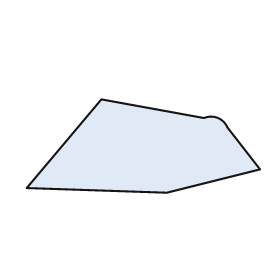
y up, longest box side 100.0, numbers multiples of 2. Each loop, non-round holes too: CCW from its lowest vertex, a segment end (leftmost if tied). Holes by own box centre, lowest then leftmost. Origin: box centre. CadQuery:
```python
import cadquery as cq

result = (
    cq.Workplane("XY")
    .moveTo(10.0, -20.0)
    .lineTo(50.0, -10.0)
    .lineTo(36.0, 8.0)
    .threePointArc((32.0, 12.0), (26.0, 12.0))
    .lineTo(-18.0, 20.0)
    .lineTo(-50.0, -18.0)
    .close()
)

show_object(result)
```